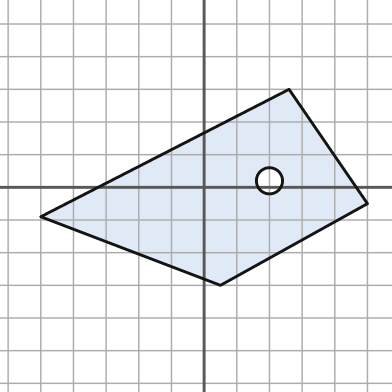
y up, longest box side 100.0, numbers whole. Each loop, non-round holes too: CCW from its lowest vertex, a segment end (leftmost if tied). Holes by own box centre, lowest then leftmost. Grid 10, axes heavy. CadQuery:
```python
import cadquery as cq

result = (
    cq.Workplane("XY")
    .moveTo(5.0, -30.0)
    .lineTo(50.0, -5.0)
    .lineTo(26.0, 30.0)
    .lineTo(-50.0, -9.0)
    .close()
    .moveTo(20.0, 2.0)
    .circle(4.0)
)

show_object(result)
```